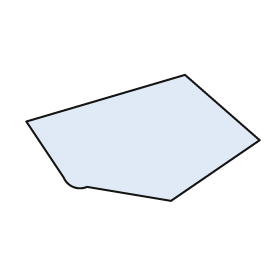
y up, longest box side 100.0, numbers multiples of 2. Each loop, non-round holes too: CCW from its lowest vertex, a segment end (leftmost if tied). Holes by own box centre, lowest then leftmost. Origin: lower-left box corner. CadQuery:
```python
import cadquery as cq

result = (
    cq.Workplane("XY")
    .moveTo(62.0, 0.0)
    .lineTo(100.0, 26.0)
    .lineTo(68.0, 54.0)
    .lineTo(0.0, 34.0)
    .lineTo(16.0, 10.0)
    .threePointArc((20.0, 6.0), (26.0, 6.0))
    .close()
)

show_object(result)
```